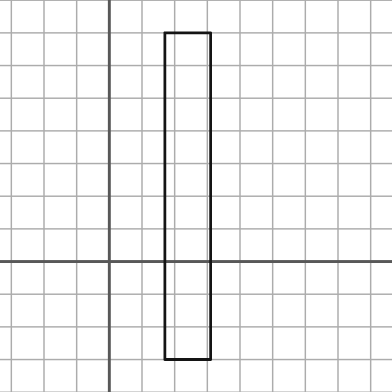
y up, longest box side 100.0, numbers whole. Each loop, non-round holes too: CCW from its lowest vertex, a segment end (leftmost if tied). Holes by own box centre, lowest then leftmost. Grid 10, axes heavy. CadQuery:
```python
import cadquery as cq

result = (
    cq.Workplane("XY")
    .moveTo(17.0, -30.0)
    .lineTo(31.0, -30.0)
    .lineTo(31.0, 70.0)
    .lineTo(17.0, 70.0)
    .close()
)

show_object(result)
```